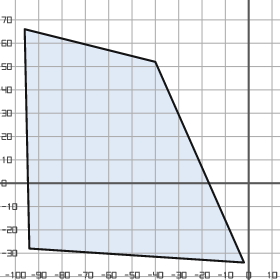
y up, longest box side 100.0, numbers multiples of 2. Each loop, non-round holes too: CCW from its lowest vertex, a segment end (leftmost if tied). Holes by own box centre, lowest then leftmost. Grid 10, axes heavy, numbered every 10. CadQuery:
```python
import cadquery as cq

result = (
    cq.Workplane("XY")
    .moveTo(-2.0, -34.0)
    .lineTo(-40.0, 52.0)
    .lineTo(-96.0, 66.0)
    .lineTo(-94.0, -28.0)
    .close()
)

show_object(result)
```